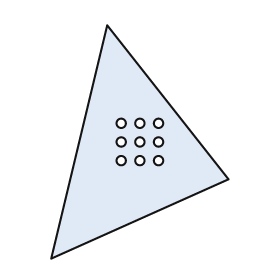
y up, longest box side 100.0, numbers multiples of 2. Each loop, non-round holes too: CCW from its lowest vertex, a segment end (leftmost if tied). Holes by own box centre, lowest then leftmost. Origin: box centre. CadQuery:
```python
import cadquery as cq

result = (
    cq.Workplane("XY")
    .moveTo(-38.0, -50.0)
    .lineTo(38.0, -16.0)
    .lineTo(-14.0, 50.0)
    .close()
    .moveTo(-8.0, -8.0)
    .circle(2.0)
    .moveTo(0.0, -8.0)
    .circle(2.0)
    .moveTo(8.0, -8.0)
    .circle(2.0)
    .moveTo(-8.0, 0.0)
    .circle(2.0)
    .moveTo(0.0, 0.0)
    .circle(2.0)
    .moveTo(8.0, 0.0)
    .circle(2.0)
    .moveTo(-8.0, 8.0)
    .circle(2.0)
    .moveTo(0.0, 8.0)
    .circle(2.0)
    .moveTo(8.0, 8.0)
    .circle(2.0)
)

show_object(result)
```